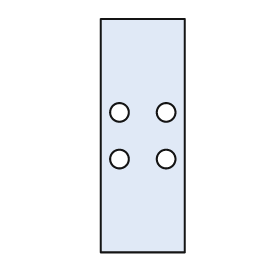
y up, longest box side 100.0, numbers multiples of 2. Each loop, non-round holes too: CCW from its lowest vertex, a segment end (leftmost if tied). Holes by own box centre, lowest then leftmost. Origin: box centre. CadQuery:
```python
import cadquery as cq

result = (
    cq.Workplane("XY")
    .moveTo(-18.0, -50.0)
    .lineTo(18.0, -50.0)
    .lineTo(18.0, 50.0)
    .lineTo(-18.0, 50.0)
    .close()
    .moveTo(-10.0, -10.0)
    .circle(4.0)
    .moveTo(10.0, -10.0)
    .circle(4.0)
    .moveTo(-10.0, 10.0)
    .circle(4.0)
    .moveTo(10.0, 10.0)
    .circle(4.0)
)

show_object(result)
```